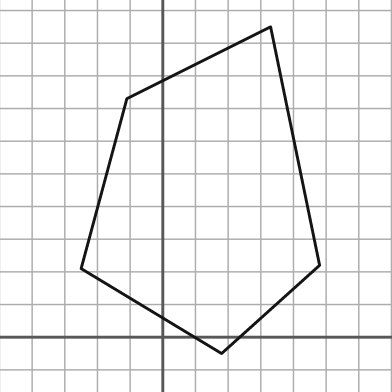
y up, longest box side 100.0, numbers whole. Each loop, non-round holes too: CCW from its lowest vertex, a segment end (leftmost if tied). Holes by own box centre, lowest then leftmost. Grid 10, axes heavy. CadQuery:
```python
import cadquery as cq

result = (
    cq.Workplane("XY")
    .moveTo(18.0, -5.0)
    .lineTo(48.0, 22.0)
    .lineTo(33.0, 95.0)
    .lineTo(-11.0, 73.0)
    .lineTo(-25.0, 21.0)
    .close()
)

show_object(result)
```